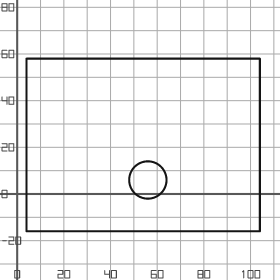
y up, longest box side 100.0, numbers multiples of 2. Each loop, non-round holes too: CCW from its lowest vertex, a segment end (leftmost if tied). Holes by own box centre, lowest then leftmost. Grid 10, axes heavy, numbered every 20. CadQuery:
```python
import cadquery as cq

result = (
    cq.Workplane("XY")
    .moveTo(4.0, -16.0)
    .lineTo(104.0, -16.0)
    .lineTo(104.0, 58.0)
    .lineTo(4.0, 58.0)
    .close()
    .moveTo(56.0, 6.0)
    .circle(8.0)
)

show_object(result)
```